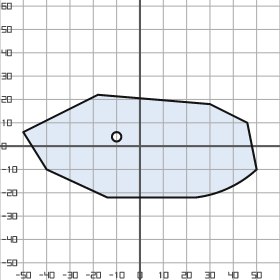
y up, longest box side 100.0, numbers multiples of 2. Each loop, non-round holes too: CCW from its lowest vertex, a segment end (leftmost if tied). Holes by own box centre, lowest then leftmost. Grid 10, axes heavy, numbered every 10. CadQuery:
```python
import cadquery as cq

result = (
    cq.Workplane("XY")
    .moveTo(-14.0, -22.0)
    .lineTo(24.0, -22.0)
    .threePointArc((38.0, -18.0), (50.0, -10.0))
    .lineTo(46.0, 10.0)
    .lineTo(30.0, 18.0)
    .lineTo(-18.0, 22.0)
    .lineTo(-50.0, 6.0)
    .lineTo(-40.0, -10.0)
    .close()
    .moveTo(-10.0, 4.0)
    .circle(2.0)
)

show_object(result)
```